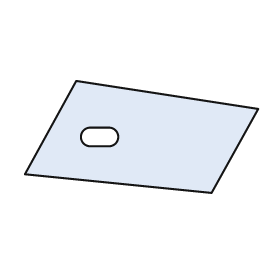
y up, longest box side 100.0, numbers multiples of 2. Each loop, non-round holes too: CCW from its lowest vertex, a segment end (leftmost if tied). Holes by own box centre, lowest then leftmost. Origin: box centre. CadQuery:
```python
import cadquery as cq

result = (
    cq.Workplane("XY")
    .moveTo(30.0, -24.0)
    .lineTo(50.0, 12.0)
    .lineTo(-28.0, 24.0)
    .lineTo(-50.0, -16.0)
    .close()
    .moveTo(-22.0, -4.0)
    .lineTo(-14.0, -4.0)
    .threePointArc((-10.0, 0.0), (-14.0, 4.0))
    .lineTo(-22.0, 4.0)
    .threePointArc((-26.0, 0.0), (-22.0, -4.0))
    .close()
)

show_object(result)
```